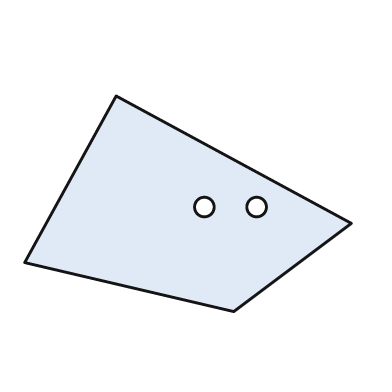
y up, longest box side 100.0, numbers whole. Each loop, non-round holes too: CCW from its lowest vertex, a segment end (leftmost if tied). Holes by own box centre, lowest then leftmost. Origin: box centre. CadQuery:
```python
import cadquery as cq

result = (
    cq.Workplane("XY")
    .moveTo(14.0, -33.0)
    .lineTo(50.0, -6.0)
    .lineTo(-22.0, 33.0)
    .lineTo(-50.0, -18.0)
    .close()
    .moveTo(5.0, -1.0)
    .circle(3.0)
    .moveTo(21.0, -1.0)
    .circle(3.0)
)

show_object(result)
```